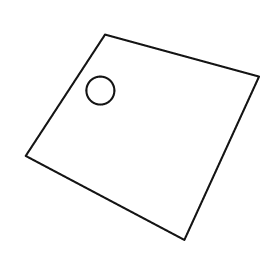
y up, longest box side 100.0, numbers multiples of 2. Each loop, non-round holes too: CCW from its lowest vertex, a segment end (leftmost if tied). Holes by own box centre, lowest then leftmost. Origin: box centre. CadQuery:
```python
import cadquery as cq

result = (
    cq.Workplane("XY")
    .moveTo(18.0, -44.0)
    .lineTo(50.0, 26.0)
    .lineTo(-16.0, 44.0)
    .lineTo(-50.0, -8.0)
    .close()
    .moveTo(-18.0, 20.0)
    .circle(6.0)
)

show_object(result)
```